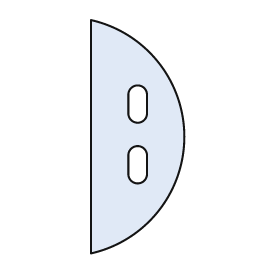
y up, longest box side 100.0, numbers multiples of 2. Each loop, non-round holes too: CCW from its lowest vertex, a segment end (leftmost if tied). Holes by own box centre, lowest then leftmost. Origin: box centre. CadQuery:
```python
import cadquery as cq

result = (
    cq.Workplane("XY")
    .moveTo(-20.0, -50.0)
    .threePointArc((20.0, 0.0), (-20.0, 50.0))
    .close()
    .moveTo(-4.0, -16.0)
    .threePointArc((0.0, -20.0), (4.0, -16.0))
    .lineTo(4.0, -8.0)
    .threePointArc((0.0, -4.0), (-4.0, -8.0))
    .close()
    .moveTo(-4.0, 10.0)
    .threePointArc((0.0, 6.0), (4.0, 10.0))
    .lineTo(4.0, 18.0)
    .threePointArc((0.0, 22.0), (-4.0, 18.0))
    .close()
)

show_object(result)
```